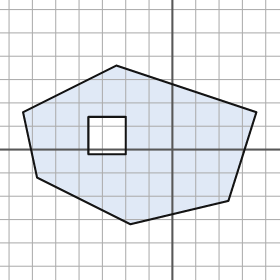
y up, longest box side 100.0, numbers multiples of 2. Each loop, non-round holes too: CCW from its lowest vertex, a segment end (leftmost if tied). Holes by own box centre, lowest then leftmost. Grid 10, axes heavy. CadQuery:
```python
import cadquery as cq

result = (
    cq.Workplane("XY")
    .moveTo(-18.0, -32.0)
    .lineTo(24.0, -22.0)
    .lineTo(36.0, 16.0)
    .lineTo(-24.0, 36.0)
    .lineTo(-64.0, 16.0)
    .lineTo(-58.0, -12.0)
    .close()
    .moveTo(-36.0, -2.0)
    .lineTo(-20.0, -2.0)
    .lineTo(-20.0, 14.0)
    .lineTo(-36.0, 14.0)
    .close()
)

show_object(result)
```